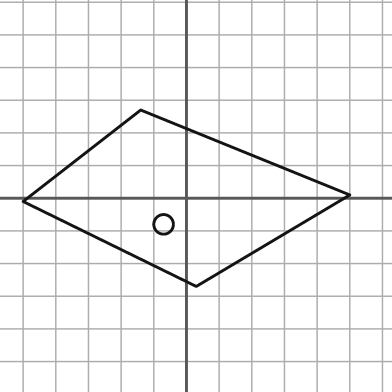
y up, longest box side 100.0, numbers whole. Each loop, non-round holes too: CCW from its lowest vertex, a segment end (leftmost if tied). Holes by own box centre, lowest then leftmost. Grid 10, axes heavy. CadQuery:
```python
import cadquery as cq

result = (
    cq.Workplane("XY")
    .moveTo(3.0, -27.0)
    .lineTo(50.0, 1.0)
    .lineTo(-14.0, 27.0)
    .lineTo(-50.0, -1.0)
    .close()
    .moveTo(-7.0, -8.0)
    .circle(3.0)
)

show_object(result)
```